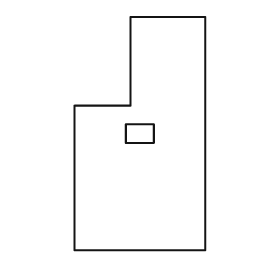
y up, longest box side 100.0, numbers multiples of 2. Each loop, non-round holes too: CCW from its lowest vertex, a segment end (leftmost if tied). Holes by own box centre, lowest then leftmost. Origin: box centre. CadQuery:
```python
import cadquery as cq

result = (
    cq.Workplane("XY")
    .moveTo(-28.0, -50.0)
    .lineTo(28.0, -50.0)
    .lineTo(28.0, 50.0)
    .lineTo(-4.0, 50.0)
    .lineTo(-4.0, 12.0)
    .lineTo(-28.0, 12.0)
    .close()
    .moveTo(-6.0, -4.0)
    .lineTo(6.0, -4.0)
    .lineTo(6.0, 4.0)
    .lineTo(-6.0, 4.0)
    .close()
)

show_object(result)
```